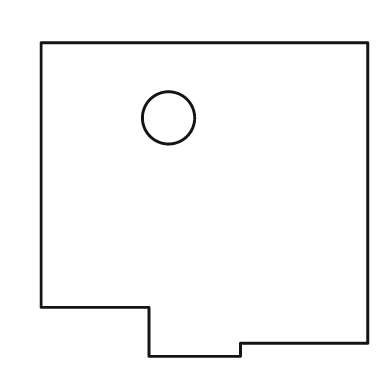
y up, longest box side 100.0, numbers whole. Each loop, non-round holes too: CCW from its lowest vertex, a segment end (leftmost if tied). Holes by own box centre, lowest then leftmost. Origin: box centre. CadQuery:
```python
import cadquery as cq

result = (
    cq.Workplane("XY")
    .moveTo(-17.0, -48.0)
    .lineTo(11.0, -48.0)
    .lineTo(11.0, -44.0)
    .lineTo(50.0, -44.0)
    .lineTo(50.0, 48.0)
    .lineTo(-50.0, 48.0)
    .lineTo(-50.0, -33.0)
    .lineTo(-17.0, -33.0)
    .close()
    .moveTo(-11.0, 25.0)
    .circle(8.0)
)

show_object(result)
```